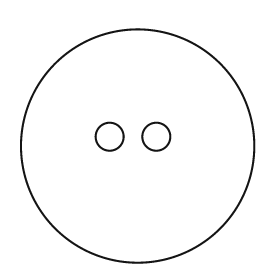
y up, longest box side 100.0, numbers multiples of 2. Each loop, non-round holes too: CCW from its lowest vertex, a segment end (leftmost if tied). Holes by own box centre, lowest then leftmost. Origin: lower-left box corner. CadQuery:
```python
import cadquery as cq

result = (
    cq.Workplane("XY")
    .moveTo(50.0, 50.0)
    .circle(50.0)
    .moveTo(38.0, 54.0)
    .circle(6.0)
    .moveTo(58.0, 54.0)
    .circle(6.0)
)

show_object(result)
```